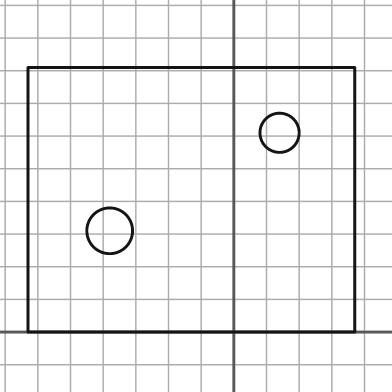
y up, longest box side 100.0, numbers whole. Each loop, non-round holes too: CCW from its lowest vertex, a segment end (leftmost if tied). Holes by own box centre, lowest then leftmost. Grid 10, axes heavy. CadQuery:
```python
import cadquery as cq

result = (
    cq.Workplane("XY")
    .moveTo(-63.0, 0.0)
    .lineTo(37.0, 0.0)
    .lineTo(37.0, 81.0)
    .lineTo(-63.0, 81.0)
    .close()
    .moveTo(-38.0, 31.0)
    .circle(7.0)
    .moveTo(14.0, 61.0)
    .circle(6.0)
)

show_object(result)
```